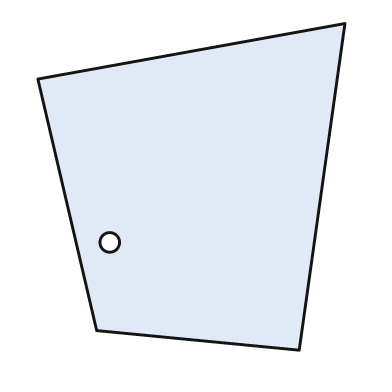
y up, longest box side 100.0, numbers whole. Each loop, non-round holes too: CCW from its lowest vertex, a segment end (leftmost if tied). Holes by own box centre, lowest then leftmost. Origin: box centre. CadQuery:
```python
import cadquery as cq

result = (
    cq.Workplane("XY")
    .moveTo(33.0, -50.0)
    .lineTo(47.0, 50.0)
    .lineTo(-47.0, 33.0)
    .lineTo(-29.0, -44.0)
    .close()
    .moveTo(-25.0, -17.0)
    .circle(3.0)
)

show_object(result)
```